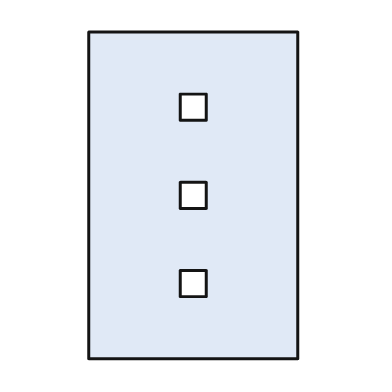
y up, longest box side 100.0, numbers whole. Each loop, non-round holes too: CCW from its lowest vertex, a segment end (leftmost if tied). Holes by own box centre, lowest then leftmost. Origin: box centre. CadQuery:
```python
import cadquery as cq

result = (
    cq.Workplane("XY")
    .moveTo(-32.0, -50.0)
    .lineTo(32.0, -50.0)
    .lineTo(32.0, 50.0)
    .lineTo(-32.0, 50.0)
    .close()
    .moveTo(-4.0, -31.0)
    .lineTo(4.0, -31.0)
    .lineTo(4.0, -23.0)
    .lineTo(-4.0, -23.0)
    .close()
    .moveTo(-4.0, -4.0)
    .lineTo(4.0, -4.0)
    .lineTo(4.0, 4.0)
    .lineTo(-4.0, 4.0)
    .close()
    .moveTo(-4.0, 23.0)
    .lineTo(4.0, 23.0)
    .lineTo(4.0, 31.0)
    .lineTo(-4.0, 31.0)
    .close()
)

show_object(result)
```